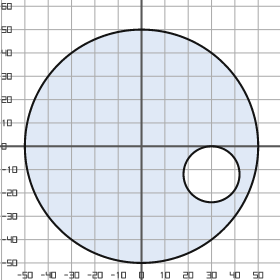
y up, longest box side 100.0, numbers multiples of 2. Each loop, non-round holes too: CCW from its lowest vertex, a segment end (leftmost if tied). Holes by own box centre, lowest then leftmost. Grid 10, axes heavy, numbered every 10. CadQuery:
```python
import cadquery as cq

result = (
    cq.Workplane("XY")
    .moveTo(0.0, 0.0)
    .circle(50.0)
    .moveTo(30.0, -12.0)
    .circle(12.0)
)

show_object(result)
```